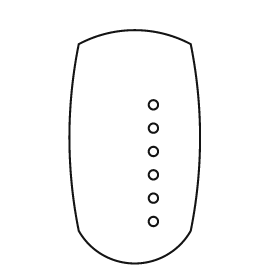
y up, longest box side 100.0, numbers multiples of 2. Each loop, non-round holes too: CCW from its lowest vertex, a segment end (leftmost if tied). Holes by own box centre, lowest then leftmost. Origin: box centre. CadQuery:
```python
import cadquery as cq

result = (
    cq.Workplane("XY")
    .moveTo(-24.0, -36.0)
    .threePointArc((0.0, -50.0), (24.0, -36.0))
    .threePointArc((28.0, 4.0), (24.0, 44.0))
    .threePointArc((0.0, 50.0), (-24.0, 44.0))
    .threePointArc((-28.0, 4.0), (-24.0, -36.0))
    .close()
    .moveTo(8.0, -32.0)
    .circle(2.0)
    .moveTo(8.0, -22.0)
    .circle(2.0)
    .moveTo(8.0, -12.0)
    .circle(2.0)
    .moveTo(8.0, -2.0)
    .circle(2.0)
    .moveTo(8.0, 8.0)
    .circle(2.0)
    .moveTo(8.0, 18.0)
    .circle(2.0)
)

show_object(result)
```